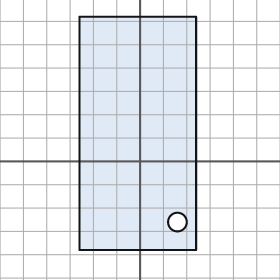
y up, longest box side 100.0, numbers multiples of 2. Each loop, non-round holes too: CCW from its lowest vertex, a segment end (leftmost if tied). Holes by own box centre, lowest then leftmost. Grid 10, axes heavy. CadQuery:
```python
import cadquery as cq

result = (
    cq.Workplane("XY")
    .moveTo(-26.0, -38.0)
    .lineTo(24.0, -38.0)
    .lineTo(24.0, 62.0)
    .lineTo(-26.0, 62.0)
    .close()
    .moveTo(16.0, -26.0)
    .circle(4.0)
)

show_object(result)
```